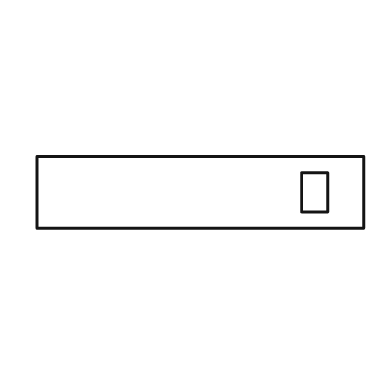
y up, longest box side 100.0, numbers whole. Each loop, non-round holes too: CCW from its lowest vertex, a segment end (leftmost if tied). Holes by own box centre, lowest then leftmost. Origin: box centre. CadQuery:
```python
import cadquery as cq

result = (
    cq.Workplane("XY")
    .moveTo(-50.0, -11.0)
    .lineTo(50.0, -11.0)
    .lineTo(50.0, 11.0)
    .lineTo(-50.0, 11.0)
    .close()
    .moveTo(31.0, -6.0)
    .lineTo(39.0, -6.0)
    .lineTo(39.0, 6.0)
    .lineTo(31.0, 6.0)
    .close()
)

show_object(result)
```